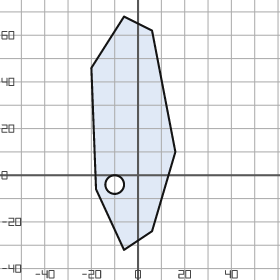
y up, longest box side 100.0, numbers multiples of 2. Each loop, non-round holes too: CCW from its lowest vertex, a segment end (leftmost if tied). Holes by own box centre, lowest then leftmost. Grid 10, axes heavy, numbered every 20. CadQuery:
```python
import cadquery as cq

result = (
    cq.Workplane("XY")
    .moveTo(-6.0, -32.0)
    .lineTo(6.0, -24.0)
    .lineTo(16.0, 10.0)
    .lineTo(6.0, 62.0)
    .lineTo(-6.0, 68.0)
    .lineTo(-20.0, 46.0)
    .lineTo(-18.0, -6.0)
    .close()
    .moveTo(-10.0, -4.0)
    .circle(4.0)
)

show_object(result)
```